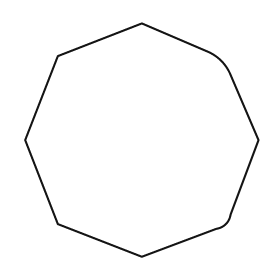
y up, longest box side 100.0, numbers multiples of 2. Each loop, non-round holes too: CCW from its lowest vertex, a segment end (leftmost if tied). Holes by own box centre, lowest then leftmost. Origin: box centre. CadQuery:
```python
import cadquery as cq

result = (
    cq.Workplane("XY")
    .moveTo(0.0, -50.0)
    .lineTo(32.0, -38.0)
    .threePointArc((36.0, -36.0), (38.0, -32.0))
    .lineTo(50.0, 0.0)
    .lineTo(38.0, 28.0)
    .threePointArc((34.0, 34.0), (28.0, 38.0))
    .lineTo(0.0, 50.0)
    .lineTo(-36.0, 36.0)
    .lineTo(-50.0, 0.0)
    .lineTo(-36.0, -36.0)
    .close()
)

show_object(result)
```